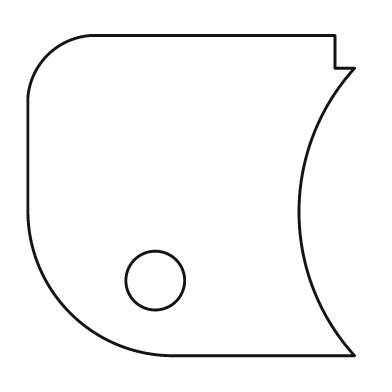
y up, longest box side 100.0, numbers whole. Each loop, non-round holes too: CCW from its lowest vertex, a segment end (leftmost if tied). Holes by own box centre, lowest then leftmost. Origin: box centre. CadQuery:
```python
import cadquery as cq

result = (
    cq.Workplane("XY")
    .moveTo(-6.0, -49.0)
    .lineTo(50.0, -49.0)
    .threePointArc((33.0, -5.0), (50.0, 39.0))
    .lineTo(44.0, 39.0)
    .lineTo(44.0, 49.0)
    .lineTo(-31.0, 49.0)
    .threePointArc((-44.0, 43.0), (-50.0, 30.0))
    .lineTo(-50.0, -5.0)
    .threePointArc((-37.0, -36.0), (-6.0, -49.0))
    .close()
    .moveTo(-11.0, -26.0)
    .circle(9.0)
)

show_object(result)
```